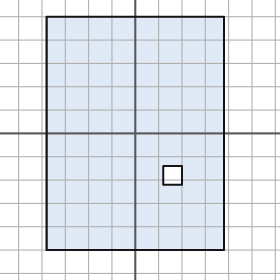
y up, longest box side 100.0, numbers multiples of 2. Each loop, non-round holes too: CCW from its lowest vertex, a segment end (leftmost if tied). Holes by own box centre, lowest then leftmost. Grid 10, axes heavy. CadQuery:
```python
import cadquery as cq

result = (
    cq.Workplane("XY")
    .moveTo(-38.0, -50.0)
    .lineTo(38.0, -50.0)
    .lineTo(38.0, 50.0)
    .lineTo(-38.0, 50.0)
    .close()
    .moveTo(12.0, -22.0)
    .lineTo(20.0, -22.0)
    .lineTo(20.0, -14.0)
    .lineTo(12.0, -14.0)
    .close()
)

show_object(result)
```